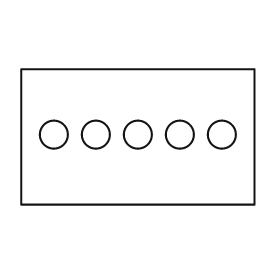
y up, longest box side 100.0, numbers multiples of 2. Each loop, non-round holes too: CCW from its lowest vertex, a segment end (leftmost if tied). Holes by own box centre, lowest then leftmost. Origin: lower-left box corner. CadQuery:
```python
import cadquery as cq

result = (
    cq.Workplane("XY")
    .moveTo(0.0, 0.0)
    .lineTo(100.0, 0.0)
    .lineTo(100.0, 58.0)
    .lineTo(0.0, 58.0)
    .close()
    .moveTo(14.0, 30.0)
    .circle(6.0)
    .moveTo(32.0, 30.0)
    .circle(6.0)
    .moveTo(50.0, 30.0)
    .circle(6.0)
    .moveTo(68.0, 30.0)
    .circle(6.0)
    .moveTo(86.0, 30.0)
    .circle(6.0)
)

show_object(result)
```